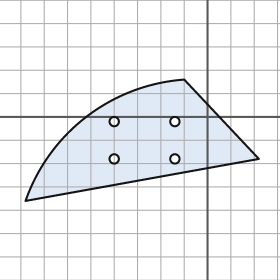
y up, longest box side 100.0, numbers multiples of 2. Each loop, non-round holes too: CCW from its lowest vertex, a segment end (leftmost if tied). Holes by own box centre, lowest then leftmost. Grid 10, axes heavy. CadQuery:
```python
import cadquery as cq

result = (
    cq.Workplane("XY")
    .moveTo(-78.0, -36.0)
    .lineTo(22.0, -18.0)
    .lineTo(-10.0, 16.0)
    .threePointArc((-52.0, 0.0), (-78.0, -36.0))
    .close()
    .moveTo(-40.0, -18.0)
    .circle(2.0)
    .moveTo(-14.0, -18.0)
    .circle(2.0)
    .moveTo(-40.0, -2.0)
    .circle(2.0)
    .moveTo(-14.0, -2.0)
    .circle(2.0)
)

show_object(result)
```